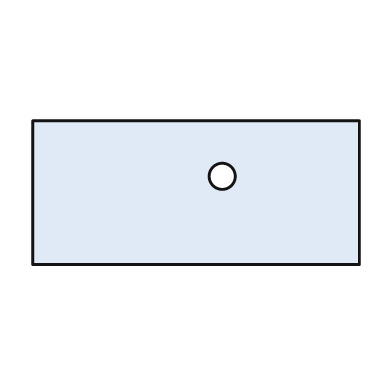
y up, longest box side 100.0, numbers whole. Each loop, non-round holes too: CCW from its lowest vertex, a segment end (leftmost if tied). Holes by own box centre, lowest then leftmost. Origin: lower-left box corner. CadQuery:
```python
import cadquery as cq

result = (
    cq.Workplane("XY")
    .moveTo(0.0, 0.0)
    .lineTo(100.0, 0.0)
    .lineTo(100.0, 44.0)
    .lineTo(0.0, 44.0)
    .close()
    .moveTo(58.0, 27.0)
    .circle(4.0)
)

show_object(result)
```